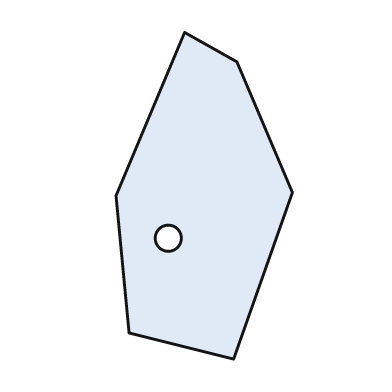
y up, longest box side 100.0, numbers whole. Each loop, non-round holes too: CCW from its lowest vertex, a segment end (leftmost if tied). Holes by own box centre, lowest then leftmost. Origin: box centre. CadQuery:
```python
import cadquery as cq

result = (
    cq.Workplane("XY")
    .moveTo(9.0, -50.0)
    .lineTo(27.0, 1.0)
    .lineTo(10.0, 41.0)
    .lineTo(-6.0, 50.0)
    .lineTo(-27.0, 0.0)
    .lineTo(-23.0, -42.0)
    .close()
    .moveTo(-11.0, -13.0)
    .circle(4.0)
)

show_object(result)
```